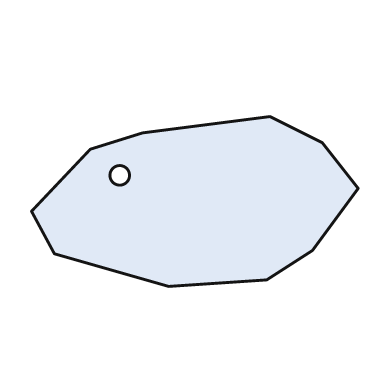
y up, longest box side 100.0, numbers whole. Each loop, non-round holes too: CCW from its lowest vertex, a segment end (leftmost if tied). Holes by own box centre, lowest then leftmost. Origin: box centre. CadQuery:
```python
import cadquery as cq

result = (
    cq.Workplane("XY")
    .moveTo(-8.0, -26.0)
    .lineTo(22.0, -24.0)
    .lineTo(36.0, -15.0)
    .lineTo(50.0, 4.0)
    .lineTo(39.0, 18.0)
    .lineTo(23.0, 26.0)
    .lineTo(-16.0, 21.0)
    .lineTo(-32.0, 16.0)
    .lineTo(-50.0, -3.0)
    .lineTo(-43.0, -16.0)
    .close()
    .moveTo(-23.0, 8.0)
    .circle(3.0)
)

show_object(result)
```